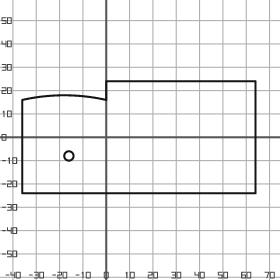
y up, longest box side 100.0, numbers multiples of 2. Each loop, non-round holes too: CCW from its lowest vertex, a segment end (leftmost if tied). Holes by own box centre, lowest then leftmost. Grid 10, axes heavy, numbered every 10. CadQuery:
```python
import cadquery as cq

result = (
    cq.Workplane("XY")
    .moveTo(-36.0, -24.0)
    .lineTo(64.0, -24.0)
    .lineTo(64.0, 24.0)
    .lineTo(0.0, 24.0)
    .lineTo(0.0, 16.0)
    .threePointArc((-18.0, 18.0), (-36.0, 16.0))
    .close()
    .moveTo(-16.0, -8.0)
    .circle(2.0)
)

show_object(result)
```